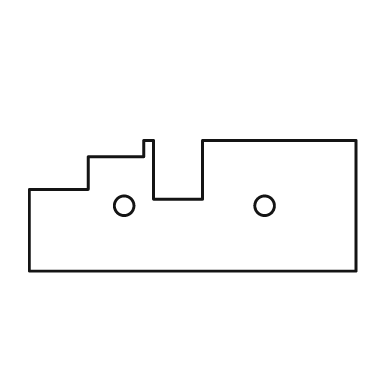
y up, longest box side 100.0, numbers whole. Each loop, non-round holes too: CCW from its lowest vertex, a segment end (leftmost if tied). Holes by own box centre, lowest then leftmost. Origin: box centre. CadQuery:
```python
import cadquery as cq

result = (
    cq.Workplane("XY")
    .moveTo(-50.0, -20.0)
    .lineTo(50.0, -20.0)
    .lineTo(50.0, 20.0)
    .lineTo(3.0, 20.0)
    .lineTo(3.0, 2.0)
    .lineTo(-12.0, 2.0)
    .lineTo(-12.0, 20.0)
    .lineTo(-15.0, 20.0)
    .lineTo(-15.0, 15.0)
    .lineTo(-32.0, 15.0)
    .lineTo(-32.0, 5.0)
    .lineTo(-50.0, 5.0)
    .close()
    .moveTo(-21.0, 0.0)
    .circle(3.0)
    .moveTo(22.0, 0.0)
    .circle(3.0)
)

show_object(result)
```